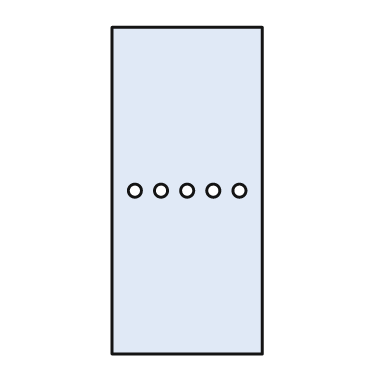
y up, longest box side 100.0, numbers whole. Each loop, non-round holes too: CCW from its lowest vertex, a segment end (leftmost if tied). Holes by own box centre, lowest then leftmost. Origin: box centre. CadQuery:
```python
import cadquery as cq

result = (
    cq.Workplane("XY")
    .moveTo(-23.0, -50.0)
    .lineTo(23.0, -50.0)
    .lineTo(23.0, 50.0)
    .lineTo(-23.0, 50.0)
    .close()
    .moveTo(-16.0, 0.0)
    .circle(2.0)
    .moveTo(-8.0, 0.0)
    .circle(2.0)
    .moveTo(0.0, 0.0)
    .circle(2.0)
    .moveTo(8.0, 0.0)
    .circle(2.0)
    .moveTo(16.0, 0.0)
    .circle(2.0)
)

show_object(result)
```